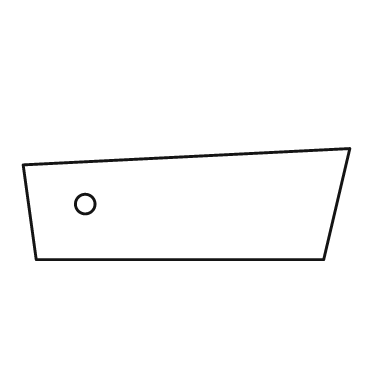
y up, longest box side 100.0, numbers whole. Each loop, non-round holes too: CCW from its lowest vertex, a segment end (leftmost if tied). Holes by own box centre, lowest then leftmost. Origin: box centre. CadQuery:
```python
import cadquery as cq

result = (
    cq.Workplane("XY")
    .moveTo(-46.0, -17.0)
    .lineTo(42.0, -17.0)
    .lineTo(50.0, 17.0)
    .lineTo(-50.0, 12.0)
    .close()
    .moveTo(-31.0, 0.0)
    .circle(3.0)
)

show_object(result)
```